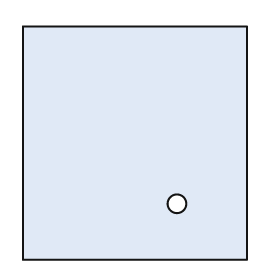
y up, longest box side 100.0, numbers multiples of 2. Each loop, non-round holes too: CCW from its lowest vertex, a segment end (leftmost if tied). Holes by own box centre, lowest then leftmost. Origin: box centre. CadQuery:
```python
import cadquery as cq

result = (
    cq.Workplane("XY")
    .moveTo(-48.0, -50.0)
    .lineTo(48.0, -50.0)
    .lineTo(48.0, 50.0)
    .lineTo(-48.0, 50.0)
    .close()
    .moveTo(18.0, -26.0)
    .circle(4.0)
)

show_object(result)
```